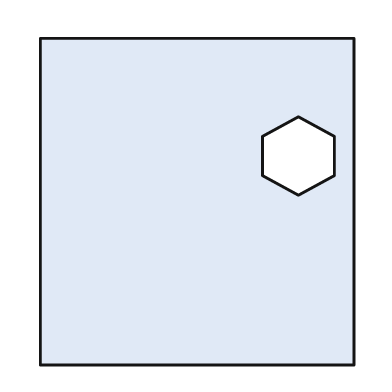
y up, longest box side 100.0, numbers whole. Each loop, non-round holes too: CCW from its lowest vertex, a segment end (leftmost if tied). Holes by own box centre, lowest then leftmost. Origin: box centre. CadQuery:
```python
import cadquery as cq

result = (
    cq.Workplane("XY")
    .moveTo(-48.0, -50.0)
    .lineTo(48.0, -50.0)
    .lineTo(48.0, 50.0)
    .lineTo(-48.0, 50.0)
    .close()
    .moveTo(31.0, 2.0)
    .lineTo(42.0, 8.0)
    .lineTo(42.0, 20.0)
    .lineTo(31.0, 26.0)
    .lineTo(20.0, 20.0)
    .lineTo(20.0, 8.0)
    .close()
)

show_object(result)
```